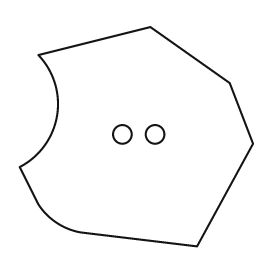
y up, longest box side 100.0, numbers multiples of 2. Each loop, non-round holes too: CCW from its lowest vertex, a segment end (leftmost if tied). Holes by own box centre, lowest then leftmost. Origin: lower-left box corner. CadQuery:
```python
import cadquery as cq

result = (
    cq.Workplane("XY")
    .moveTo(76.0, 0.0)
    .lineTo(100.0, 44.0)
    .lineTo(90.0, 70.0)
    .lineTo(56.0, 94.0)
    .lineTo(8.0, 82.0)
    .threePointArc((16.0, 56.0), (0.0, 34.0))
    .lineTo(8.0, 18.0)
    .threePointArc((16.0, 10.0), (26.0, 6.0))
    .close()
    .moveTo(44.0, 48.0)
    .circle(4.0)
    .moveTo(58.0, 48.0)
    .circle(4.0)
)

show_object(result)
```